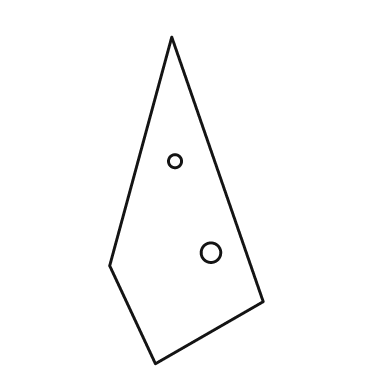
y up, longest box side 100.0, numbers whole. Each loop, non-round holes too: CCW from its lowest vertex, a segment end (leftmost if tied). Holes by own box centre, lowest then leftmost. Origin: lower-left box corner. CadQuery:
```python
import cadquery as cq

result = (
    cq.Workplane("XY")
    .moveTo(14.0, 0.0)
    .lineTo(47.0, 19.0)
    .lineTo(19.0, 100.0)
    .lineTo(0.0, 30.0)
    .close()
    .moveTo(31.0, 34.0)
    .circle(3.0)
    .moveTo(20.0, 62.0)
    .circle(2.0)
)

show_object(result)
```